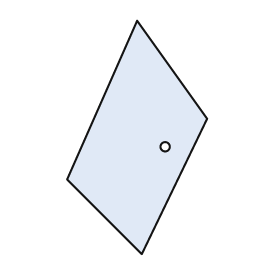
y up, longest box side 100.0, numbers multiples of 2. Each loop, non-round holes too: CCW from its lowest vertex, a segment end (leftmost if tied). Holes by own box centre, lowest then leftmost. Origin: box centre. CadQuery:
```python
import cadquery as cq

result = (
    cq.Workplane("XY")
    .moveTo(2.0, -50.0)
    .lineTo(30.0, 8.0)
    .lineTo(0.0, 50.0)
    .lineTo(-30.0, -18.0)
    .close()
    .moveTo(12.0, -4.0)
    .circle(2.0)
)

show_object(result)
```